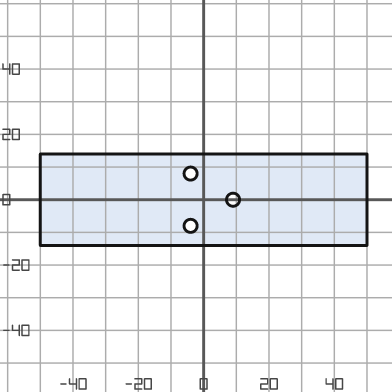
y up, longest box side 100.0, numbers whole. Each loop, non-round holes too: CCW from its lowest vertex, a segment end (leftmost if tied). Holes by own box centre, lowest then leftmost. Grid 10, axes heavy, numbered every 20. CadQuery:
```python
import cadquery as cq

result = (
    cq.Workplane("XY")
    .moveTo(-50.0, -14.0)
    .lineTo(50.0, -14.0)
    .lineTo(50.0, 14.0)
    .lineTo(-50.0, 14.0)
    .close()
    .moveTo(-4.0, -8.0)
    .circle(2.0)
    .moveTo(9.0, 0.0)
    .circle(2.0)
    .moveTo(-4.0, 8.0)
    .circle(2.0)
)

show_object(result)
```